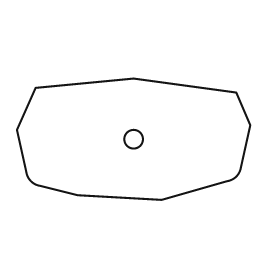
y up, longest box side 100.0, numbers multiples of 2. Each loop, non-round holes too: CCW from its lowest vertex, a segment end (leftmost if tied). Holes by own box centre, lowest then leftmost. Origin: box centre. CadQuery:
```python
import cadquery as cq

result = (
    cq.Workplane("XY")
    .moveTo(12.0, -26.0)
    .lineTo(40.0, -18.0)
    .threePointArc((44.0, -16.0), (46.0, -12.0))
    .lineTo(50.0, 6.0)
    .lineTo(44.0, 20.0)
    .lineTo(0.0, 26.0)
    .lineTo(-42.0, 22.0)
    .lineTo(-50.0, 4.0)
    .lineTo(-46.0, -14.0)
    .threePointArc((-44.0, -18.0), (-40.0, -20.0))
    .lineTo(-24.0, -24.0)
    .close()
    .moveTo(0.0, 0.0)
    .circle(4.0)
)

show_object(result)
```